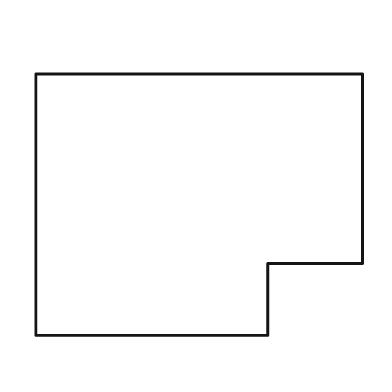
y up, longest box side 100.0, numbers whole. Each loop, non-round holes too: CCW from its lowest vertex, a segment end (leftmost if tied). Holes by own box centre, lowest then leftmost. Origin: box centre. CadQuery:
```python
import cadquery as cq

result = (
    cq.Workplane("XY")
    .moveTo(-50.0, -40.0)
    .lineTo(21.0, -40.0)
    .lineTo(21.0, -18.0)
    .lineTo(50.0, -18.0)
    .lineTo(50.0, 40.0)
    .lineTo(-50.0, 40.0)
    .close()
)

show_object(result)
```